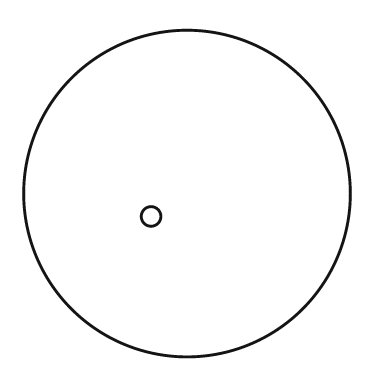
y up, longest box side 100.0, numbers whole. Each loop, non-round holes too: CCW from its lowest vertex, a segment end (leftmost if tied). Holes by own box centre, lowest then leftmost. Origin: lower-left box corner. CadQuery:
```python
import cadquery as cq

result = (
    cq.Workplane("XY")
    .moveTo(50.0, 50.0)
    .circle(50.0)
    .moveTo(39.0, 43.0)
    .circle(3.0)
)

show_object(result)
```